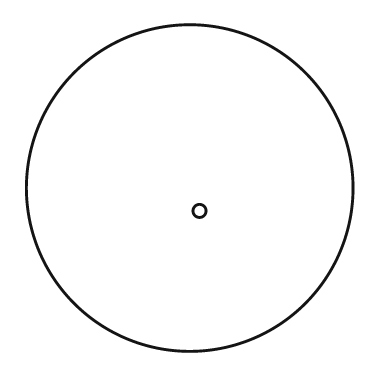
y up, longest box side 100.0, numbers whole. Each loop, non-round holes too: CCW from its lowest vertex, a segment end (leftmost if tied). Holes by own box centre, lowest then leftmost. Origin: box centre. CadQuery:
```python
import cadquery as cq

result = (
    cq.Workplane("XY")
    .moveTo(0.0, 0.0)
    .circle(50.0)
    .moveTo(3.0, -7.0)
    .circle(2.0)
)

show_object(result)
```